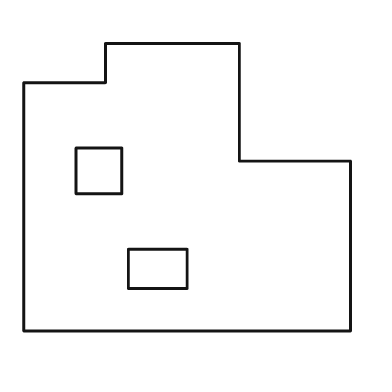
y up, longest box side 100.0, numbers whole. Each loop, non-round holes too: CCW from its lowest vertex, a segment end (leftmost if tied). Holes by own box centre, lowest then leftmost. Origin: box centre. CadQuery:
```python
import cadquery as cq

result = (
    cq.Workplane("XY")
    .moveTo(-50.0, -44.0)
    .lineTo(50.0, -44.0)
    .lineTo(50.0, 8.0)
    .lineTo(16.0, 8.0)
    .lineTo(16.0, 44.0)
    .lineTo(-25.0, 44.0)
    .lineTo(-25.0, 32.0)
    .lineTo(-50.0, 32.0)
    .close()
    .moveTo(-18.0, -31.0)
    .lineTo(0.0, -31.0)
    .lineTo(0.0, -19.0)
    .lineTo(-18.0, -19.0)
    .close()
    .moveTo(-34.0, -2.0)
    .lineTo(-20.0, -2.0)
    .lineTo(-20.0, 12.0)
    .lineTo(-34.0, 12.0)
    .close()
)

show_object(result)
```